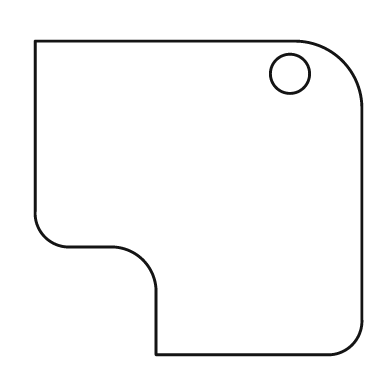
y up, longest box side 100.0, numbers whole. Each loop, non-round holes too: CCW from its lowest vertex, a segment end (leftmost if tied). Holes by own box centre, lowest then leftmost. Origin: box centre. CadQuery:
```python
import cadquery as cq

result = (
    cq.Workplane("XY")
    .moveTo(-13.0, -48.0)
    .lineTo(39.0, -48.0)
    .threePointArc((47.0, -45.0), (50.0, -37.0))
    .lineTo(50.0, 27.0)
    .threePointArc((44.0, 42.0), (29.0, 48.0))
    .lineTo(-50.0, 48.0)
    .lineTo(-50.0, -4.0)
    .threePointArc((-47.0, -12.0), (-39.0, -15.0))
    .lineTo(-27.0, -15.0)
    .threePointArc((-17.0, -19.0), (-13.0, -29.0))
    .close()
    .moveTo(28.0, 38.0)
    .circle(6.0)
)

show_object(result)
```